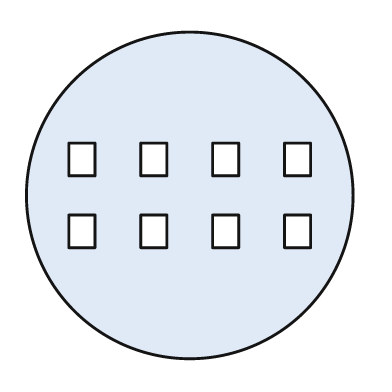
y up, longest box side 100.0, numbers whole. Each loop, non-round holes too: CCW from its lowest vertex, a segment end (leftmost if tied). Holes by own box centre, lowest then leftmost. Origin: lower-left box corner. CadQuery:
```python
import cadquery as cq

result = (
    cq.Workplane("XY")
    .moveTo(50.0, 50.0)
    .circle(50.0)
    .moveTo(13.0, 34.0)
    .lineTo(21.0, 34.0)
    .lineTo(21.0, 44.0)
    .lineTo(13.0, 44.0)
    .close()
    .moveTo(35.0, 34.0)
    .lineTo(43.0, 34.0)
    .lineTo(43.0, 44.0)
    .lineTo(35.0, 44.0)
    .close()
    .moveTo(57.0, 34.0)
    .lineTo(65.0, 34.0)
    .lineTo(65.0, 44.0)
    .lineTo(57.0, 44.0)
    .close()
    .moveTo(79.0, 34.0)
    .lineTo(87.0, 34.0)
    .lineTo(87.0, 44.0)
    .lineTo(79.0, 44.0)
    .close()
    .moveTo(13.0, 56.0)
    .lineTo(21.0, 56.0)
    .lineTo(21.0, 66.0)
    .lineTo(13.0, 66.0)
    .close()
    .moveTo(35.0, 56.0)
    .lineTo(43.0, 56.0)
    .lineTo(43.0, 66.0)
    .lineTo(35.0, 66.0)
    .close()
    .moveTo(57.0, 56.0)
    .lineTo(65.0, 56.0)
    .lineTo(65.0, 66.0)
    .lineTo(57.0, 66.0)
    .close()
    .moveTo(79.0, 56.0)
    .lineTo(87.0, 56.0)
    .lineTo(87.0, 66.0)
    .lineTo(79.0, 66.0)
    .close()
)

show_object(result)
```